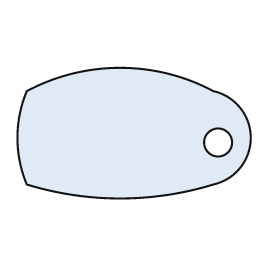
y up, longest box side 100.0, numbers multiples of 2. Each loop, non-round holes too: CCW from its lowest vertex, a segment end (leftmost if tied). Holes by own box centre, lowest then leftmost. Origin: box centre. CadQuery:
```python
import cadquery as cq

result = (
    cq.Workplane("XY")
    .moveTo(-46.0, -22.0)
    .threePointArc((-6.0, -28.0), (34.0, -22.0))
    .threePointArc((50.0, -2.0), (34.0, 18.0))
    .threePointArc((-6.0, 28.0), (-46.0, 18.0))
    .threePointArc((-50.0, -2.0), (-46.0, -22.0))
    .close()
    .moveTo(36.0, -4.0)
    .circle(6.0)
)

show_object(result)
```